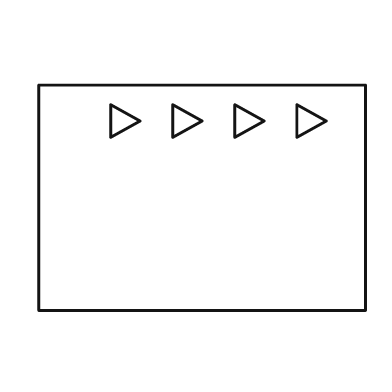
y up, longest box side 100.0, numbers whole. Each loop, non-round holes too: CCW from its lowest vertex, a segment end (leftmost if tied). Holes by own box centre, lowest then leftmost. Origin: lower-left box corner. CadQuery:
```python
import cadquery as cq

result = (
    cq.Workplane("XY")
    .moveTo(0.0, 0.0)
    .lineTo(100.0, 0.0)
    .lineTo(100.0, 69.0)
    .lineTo(0.0, 69.0)
    .close()
    .moveTo(22.0, 53.0)
    .lineTo(31.0, 58.0)
    .lineTo(22.0, 63.0)
    .close()
    .moveTo(41.0, 53.0)
    .lineTo(50.0, 58.0)
    .lineTo(41.0, 63.0)
    .close()
    .moveTo(60.0, 53.0)
    .lineTo(69.0, 58.0)
    .lineTo(60.0, 63.0)
    .close()
    .moveTo(79.0, 53.0)
    .lineTo(88.0, 58.0)
    .lineTo(79.0, 63.0)
    .close()
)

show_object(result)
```